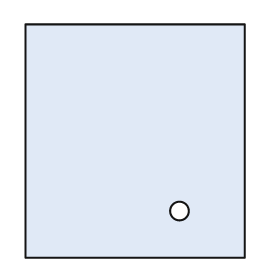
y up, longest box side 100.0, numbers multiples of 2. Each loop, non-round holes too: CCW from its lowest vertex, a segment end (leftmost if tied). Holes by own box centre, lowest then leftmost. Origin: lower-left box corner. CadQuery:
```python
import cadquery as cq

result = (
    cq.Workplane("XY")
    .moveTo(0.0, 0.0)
    .lineTo(94.0, 0.0)
    .lineTo(94.0, 100.0)
    .lineTo(0.0, 100.0)
    .close()
    .moveTo(66.0, 20.0)
    .circle(4.0)
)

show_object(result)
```